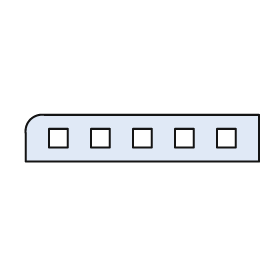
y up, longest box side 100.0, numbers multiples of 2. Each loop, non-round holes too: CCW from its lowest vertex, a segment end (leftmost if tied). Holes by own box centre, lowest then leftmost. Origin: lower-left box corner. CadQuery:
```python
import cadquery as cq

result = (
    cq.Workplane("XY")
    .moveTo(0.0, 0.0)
    .lineTo(100.0, 0.0)
    .lineTo(100.0, 20.0)
    .lineTo(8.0, 20.0)
    .threePointArc((2.0, 18.0), (0.0, 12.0))
    .close()
    .moveTo(10.0, 6.0)
    .lineTo(18.0, 6.0)
    .lineTo(18.0, 14.0)
    .lineTo(10.0, 14.0)
    .close()
    .moveTo(28.0, 6.0)
    .lineTo(36.0, 6.0)
    .lineTo(36.0, 14.0)
    .lineTo(28.0, 14.0)
    .close()
    .moveTo(46.0, 6.0)
    .lineTo(54.0, 6.0)
    .lineTo(54.0, 14.0)
    .lineTo(46.0, 14.0)
    .close()
    .moveTo(64.0, 6.0)
    .lineTo(72.0, 6.0)
    .lineTo(72.0, 14.0)
    .lineTo(64.0, 14.0)
    .close()
    .moveTo(82.0, 6.0)
    .lineTo(90.0, 6.0)
    .lineTo(90.0, 14.0)
    .lineTo(82.0, 14.0)
    .close()
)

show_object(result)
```